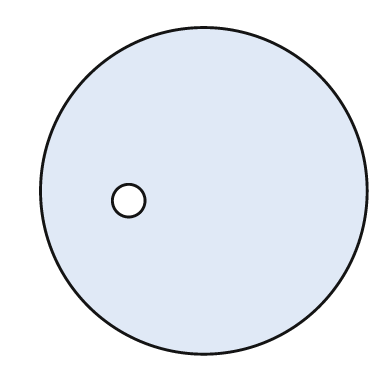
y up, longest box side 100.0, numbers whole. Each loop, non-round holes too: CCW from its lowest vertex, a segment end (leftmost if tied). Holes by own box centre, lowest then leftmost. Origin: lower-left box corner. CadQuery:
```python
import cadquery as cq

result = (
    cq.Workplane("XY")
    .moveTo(50.0, 50.0)
    .circle(50.0)
    .moveTo(27.0, 47.0)
    .circle(5.0)
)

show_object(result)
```